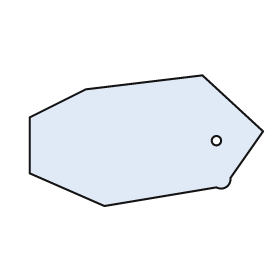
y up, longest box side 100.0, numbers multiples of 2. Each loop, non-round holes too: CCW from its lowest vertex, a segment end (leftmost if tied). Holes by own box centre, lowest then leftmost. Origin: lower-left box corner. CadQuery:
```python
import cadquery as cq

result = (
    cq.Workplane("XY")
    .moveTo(32.0, 0.0)
    .lineTo(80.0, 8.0)
    .threePointArc((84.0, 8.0), (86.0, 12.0))
    .lineTo(100.0, 32.0)
    .lineTo(74.0, 56.0)
    .lineTo(24.0, 50.0)
    .lineTo(0.0, 38.0)
    .lineTo(0.0, 14.0)
    .close()
    .moveTo(80.0, 28.0)
    .circle(2.0)
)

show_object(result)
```